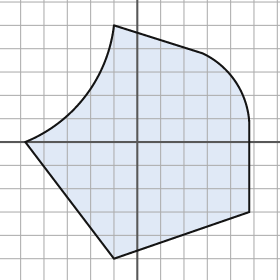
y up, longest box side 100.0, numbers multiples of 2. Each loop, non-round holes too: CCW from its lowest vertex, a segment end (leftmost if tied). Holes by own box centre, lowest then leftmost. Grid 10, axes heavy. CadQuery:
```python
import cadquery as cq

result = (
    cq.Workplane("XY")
    .moveTo(-10.0, -50.0)
    .lineTo(48.0, -30.0)
    .lineTo(48.0, 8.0)
    .threePointArc((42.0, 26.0), (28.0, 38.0))
    .lineTo(-10.0, 50.0)
    .threePointArc((-22.0, 20.0), (-48.0, 0.0))
    .close()
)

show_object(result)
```